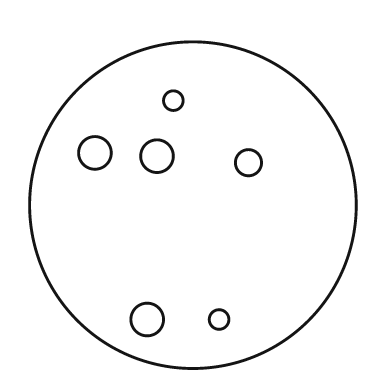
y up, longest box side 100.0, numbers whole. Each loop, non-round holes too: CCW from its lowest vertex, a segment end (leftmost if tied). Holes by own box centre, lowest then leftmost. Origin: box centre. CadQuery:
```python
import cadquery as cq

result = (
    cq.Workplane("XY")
    .moveTo(0.0, 0.0)
    .circle(50.0)
    .moveTo(-14.0, -35.0)
    .circle(5.0)
    .moveTo(8.0, -35.0)
    .circle(3.0)
    .moveTo(17.0, 13.0)
    .circle(4.0)
    .moveTo(-11.0, 15.0)
    .circle(5.0)
    .moveTo(-30.0, 16.0)
    .circle(5.0)
    .moveTo(-6.0, 32.0)
    .circle(3.0)
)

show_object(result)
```